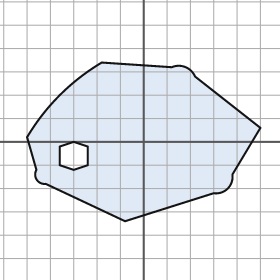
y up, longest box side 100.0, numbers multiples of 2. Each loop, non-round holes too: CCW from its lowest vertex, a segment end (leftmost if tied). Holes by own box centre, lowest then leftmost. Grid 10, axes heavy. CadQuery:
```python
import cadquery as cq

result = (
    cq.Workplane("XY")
    .moveTo(-8.0, -34.0)
    .lineTo(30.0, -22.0)
    .threePointArc((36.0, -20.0), (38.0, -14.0))
    .lineTo(50.0, 6.0)
    .lineTo(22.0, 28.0)
    .threePointArc((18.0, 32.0), (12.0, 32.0))
    .lineTo(-18.0, 34.0)
    .threePointArc((-36.0, 20.0), (-50.0, 2.0))
    .lineTo(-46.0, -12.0)
    .threePointArc((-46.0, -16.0), (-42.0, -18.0))
    .close()
    .moveTo(-30.0, -12.0)
    .lineTo(-24.0, -10.0)
    .lineTo(-24.0, -2.0)
    .lineTo(-30.0, 0.0)
    .lineTo(-36.0, -2.0)
    .lineTo(-36.0, -10.0)
    .close()
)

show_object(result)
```